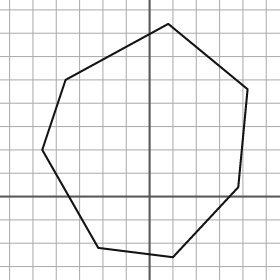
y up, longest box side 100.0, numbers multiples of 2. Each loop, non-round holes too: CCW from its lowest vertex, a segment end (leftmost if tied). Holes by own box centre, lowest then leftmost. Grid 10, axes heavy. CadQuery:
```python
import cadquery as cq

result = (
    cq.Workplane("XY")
    .moveTo(10.0, -26.0)
    .lineTo(38.0, 4.0)
    .lineTo(42.0, 46.0)
    .lineTo(8.0, 74.0)
    .lineTo(-36.0, 50.0)
    .lineTo(-46.0, 20.0)
    .lineTo(-22.0, -22.0)
    .close()
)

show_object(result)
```